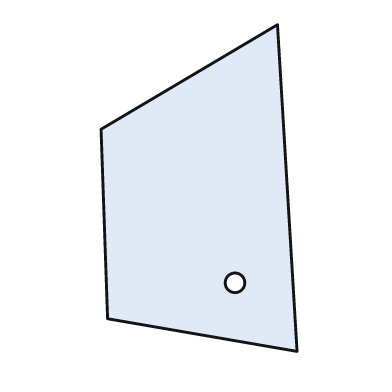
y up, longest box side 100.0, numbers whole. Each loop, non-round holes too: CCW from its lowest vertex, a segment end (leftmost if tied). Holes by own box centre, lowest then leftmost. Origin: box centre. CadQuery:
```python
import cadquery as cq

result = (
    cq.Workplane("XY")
    .moveTo(30.0, -50.0)
    .lineTo(24.0, 50.0)
    .lineTo(-30.0, 18.0)
    .lineTo(-28.0, -40.0)
    .close()
    .moveTo(11.0, -29.0)
    .circle(3.0)
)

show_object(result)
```